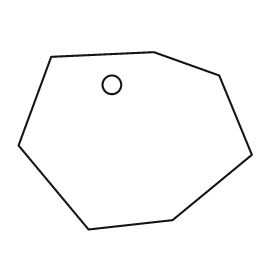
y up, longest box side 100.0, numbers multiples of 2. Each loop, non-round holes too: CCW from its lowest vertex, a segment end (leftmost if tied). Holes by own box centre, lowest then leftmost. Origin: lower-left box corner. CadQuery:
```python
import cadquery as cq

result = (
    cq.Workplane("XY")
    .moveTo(30.0, 0.0)
    .lineTo(66.0, 4.0)
    .lineTo(100.0, 32.0)
    .lineTo(86.0, 66.0)
    .lineTo(58.0, 76.0)
    .lineTo(14.0, 74.0)
    .lineTo(0.0, 36.0)
    .close()
    .moveTo(40.0, 62.0)
    .circle(4.0)
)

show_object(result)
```